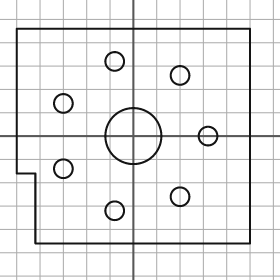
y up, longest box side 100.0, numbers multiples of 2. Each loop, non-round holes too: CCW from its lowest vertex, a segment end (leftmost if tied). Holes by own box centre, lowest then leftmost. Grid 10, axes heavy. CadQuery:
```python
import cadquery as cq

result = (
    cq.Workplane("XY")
    .moveTo(-42.0, -46.0)
    .lineTo(50.0, -46.0)
    .lineTo(50.0, 46.0)
    .lineTo(-50.0, 46.0)
    .lineTo(-50.0, -16.0)
    .lineTo(-42.0, -16.0)
    .close()
    .moveTo(-8.0, -32.0)
    .circle(4.0)
    .moveTo(20.0, -26.0)
    .circle(4.0)
    .moveTo(-30.0, -14.0)
    .circle(4.0)
    .moveTo(0.0, 0.0)
    .circle(12.0)
    .moveTo(32.0, 0.0)
    .circle(4.0)
    .moveTo(-30.0, 14.0)
    .circle(4.0)
    .moveTo(20.0, 26.0)
    .circle(4.0)
    .moveTo(-8.0, 32.0)
    .circle(4.0)
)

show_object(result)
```